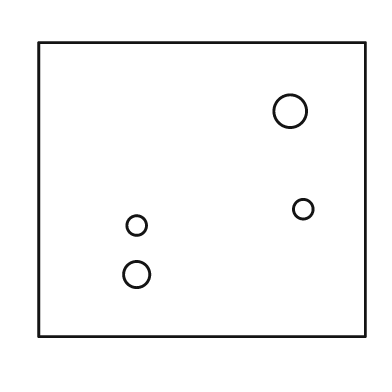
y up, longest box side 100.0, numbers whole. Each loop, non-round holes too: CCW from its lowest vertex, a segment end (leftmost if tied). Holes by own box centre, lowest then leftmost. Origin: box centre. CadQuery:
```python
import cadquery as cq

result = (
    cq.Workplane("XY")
    .moveTo(-50.0, -45.0)
    .lineTo(50.0, -45.0)
    .lineTo(50.0, 45.0)
    .lineTo(-50.0, 45.0)
    .close()
    .moveTo(-20.0, -26.0)
    .circle(4.0)
    .moveTo(-20.0, -11.0)
    .circle(3.0)
    .moveTo(31.0, -6.0)
    .circle(3.0)
    .moveTo(27.0, 24.0)
    .circle(5.0)
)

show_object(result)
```